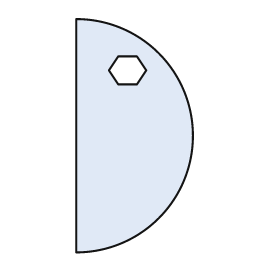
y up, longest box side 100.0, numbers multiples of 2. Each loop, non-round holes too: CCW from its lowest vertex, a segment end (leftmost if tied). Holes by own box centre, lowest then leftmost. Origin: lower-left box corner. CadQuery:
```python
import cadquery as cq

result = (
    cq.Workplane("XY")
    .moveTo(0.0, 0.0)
    .threePointArc((50.0, 50.0), (0.0, 100.0))
    .close()
    .moveTo(18.0, 72.0)
    .lineTo(26.0, 72.0)
    .lineTo(30.0, 78.0)
    .lineTo(26.0, 84.0)
    .lineTo(18.0, 84.0)
    .lineTo(14.0, 78.0)
    .close()
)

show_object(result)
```